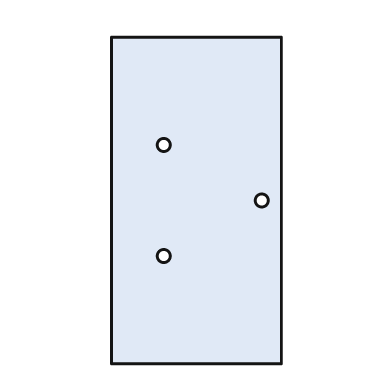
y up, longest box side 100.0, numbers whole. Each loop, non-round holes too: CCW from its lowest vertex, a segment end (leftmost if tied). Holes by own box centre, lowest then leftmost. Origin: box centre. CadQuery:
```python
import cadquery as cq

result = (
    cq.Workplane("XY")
    .moveTo(-26.0, -50.0)
    .lineTo(26.0, -50.0)
    .lineTo(26.0, 50.0)
    .lineTo(-26.0, 50.0)
    .close()
    .moveTo(-10.0, -17.0)
    .circle(2.0)
    .moveTo(20.0, 0.0)
    .circle(2.0)
    .moveTo(-10.0, 17.0)
    .circle(2.0)
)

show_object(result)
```